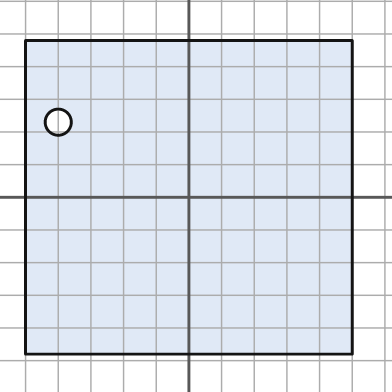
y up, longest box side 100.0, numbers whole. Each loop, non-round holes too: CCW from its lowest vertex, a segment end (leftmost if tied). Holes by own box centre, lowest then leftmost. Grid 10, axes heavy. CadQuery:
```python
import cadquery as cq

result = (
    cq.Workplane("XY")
    .moveTo(-50.0, -48.0)
    .lineTo(50.0, -48.0)
    .lineTo(50.0, 48.0)
    .lineTo(-50.0, 48.0)
    .close()
    .moveTo(-40.0, 23.0)
    .circle(4.0)
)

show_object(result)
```